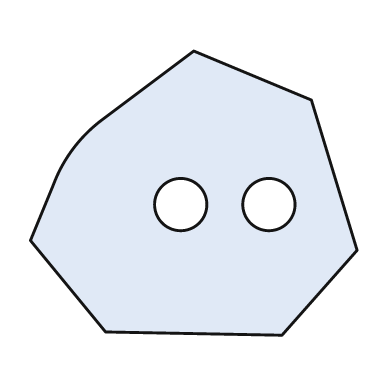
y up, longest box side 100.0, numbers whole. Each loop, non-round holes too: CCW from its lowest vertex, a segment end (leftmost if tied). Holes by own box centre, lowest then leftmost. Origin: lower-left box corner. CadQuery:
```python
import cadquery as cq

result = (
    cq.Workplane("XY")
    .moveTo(77.0, 0.0)
    .lineTo(100.0, 26.0)
    .lineTo(86.0, 72.0)
    .lineTo(50.0, 87.0)
    .lineTo(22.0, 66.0)
    .threePointArc((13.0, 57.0), (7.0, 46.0))
    .lineTo(0.0, 29.0)
    .lineTo(23.0, 1.0)
    .close()
    .moveTo(46.0, 40.0)
    .circle(8.0)
    .moveTo(73.0, 40.0)
    .circle(8.0)
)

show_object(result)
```